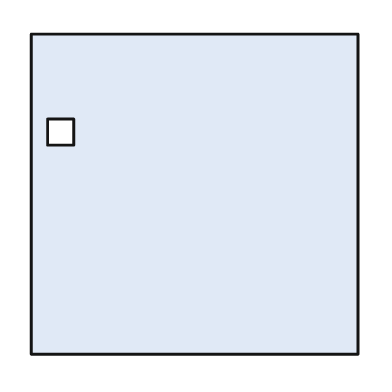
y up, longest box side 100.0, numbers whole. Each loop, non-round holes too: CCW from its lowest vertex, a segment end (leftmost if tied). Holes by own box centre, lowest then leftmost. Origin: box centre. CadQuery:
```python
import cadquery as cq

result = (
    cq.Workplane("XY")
    .moveTo(-50.0, -49.0)
    .lineTo(50.0, -49.0)
    .lineTo(50.0, 49.0)
    .lineTo(-50.0, 49.0)
    .close()
    .moveTo(-45.0, 15.0)
    .lineTo(-37.0, 15.0)
    .lineTo(-37.0, 23.0)
    .lineTo(-45.0, 23.0)
    .close()
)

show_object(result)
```